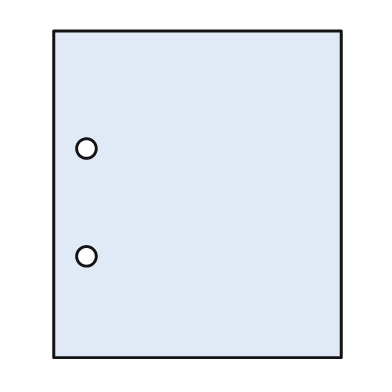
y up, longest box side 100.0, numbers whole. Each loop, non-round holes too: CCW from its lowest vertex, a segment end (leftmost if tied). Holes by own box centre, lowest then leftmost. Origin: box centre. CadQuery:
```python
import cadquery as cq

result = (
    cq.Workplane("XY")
    .moveTo(-44.0, -50.0)
    .lineTo(44.0, -50.0)
    .lineTo(44.0, 50.0)
    .lineTo(-44.0, 50.0)
    .close()
    .moveTo(-34.0, -19.0)
    .circle(3.0)
    .moveTo(-34.0, 14.0)
    .circle(3.0)
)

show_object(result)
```